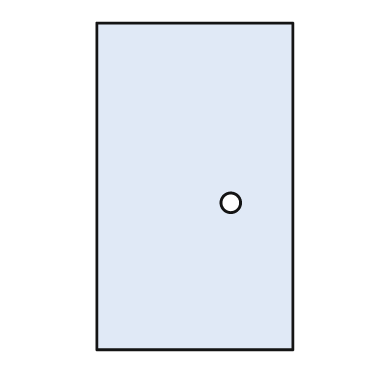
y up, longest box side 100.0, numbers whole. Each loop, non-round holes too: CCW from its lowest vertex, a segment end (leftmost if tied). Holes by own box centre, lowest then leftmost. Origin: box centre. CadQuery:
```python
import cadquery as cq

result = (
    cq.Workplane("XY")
    .moveTo(-30.0, -50.0)
    .lineTo(30.0, -50.0)
    .lineTo(30.0, 50.0)
    .lineTo(-30.0, 50.0)
    .close()
    .moveTo(11.0, -5.0)
    .circle(3.0)
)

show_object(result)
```